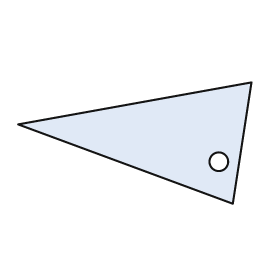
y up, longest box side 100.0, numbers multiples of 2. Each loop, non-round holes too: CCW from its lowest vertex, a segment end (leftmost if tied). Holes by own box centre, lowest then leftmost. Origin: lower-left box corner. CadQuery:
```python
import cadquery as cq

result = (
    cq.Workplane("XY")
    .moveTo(92.0, 0.0)
    .lineTo(100.0, 52.0)
    .lineTo(0.0, 34.0)
    .close()
    .moveTo(86.0, 18.0)
    .circle(4.0)
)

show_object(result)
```